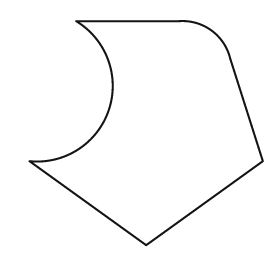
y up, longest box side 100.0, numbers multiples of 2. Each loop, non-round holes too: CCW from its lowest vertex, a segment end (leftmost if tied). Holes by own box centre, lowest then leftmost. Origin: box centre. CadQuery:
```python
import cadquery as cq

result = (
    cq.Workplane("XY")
    .moveTo(0.0, -48.0)
    .lineTo(50.0, -12.0)
    .lineTo(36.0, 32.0)
    .threePointArc((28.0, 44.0), (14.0, 48.0))
    .lineTo(-30.0, 48.0)
    .threePointArc((-16.0, 10.0), (-50.0, -12.0))
    .close()
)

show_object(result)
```